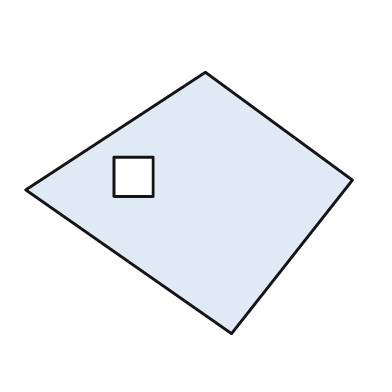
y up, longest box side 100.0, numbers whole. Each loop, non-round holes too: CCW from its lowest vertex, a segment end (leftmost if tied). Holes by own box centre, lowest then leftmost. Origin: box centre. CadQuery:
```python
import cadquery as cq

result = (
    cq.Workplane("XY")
    .moveTo(13.0, -40.0)
    .lineTo(50.0, 7.0)
    .lineTo(5.0, 40.0)
    .lineTo(-50.0, 4.0)
    .close()
    .moveTo(-23.0, 2.0)
    .lineTo(-11.0, 2.0)
    .lineTo(-11.0, 14.0)
    .lineTo(-23.0, 14.0)
    .close()
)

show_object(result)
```